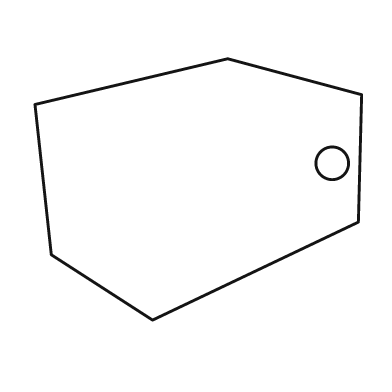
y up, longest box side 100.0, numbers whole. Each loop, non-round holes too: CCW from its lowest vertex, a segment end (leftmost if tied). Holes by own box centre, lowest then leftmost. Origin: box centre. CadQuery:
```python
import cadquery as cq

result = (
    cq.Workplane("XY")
    .moveTo(-14.0, -40.0)
    .lineTo(49.0, -10.0)
    .lineTo(50.0, 29.0)
    .lineTo(9.0, 40.0)
    .lineTo(-50.0, 26.0)
    .lineTo(-45.0, -20.0)
    .close()
    .moveTo(41.0, 8.0)
    .circle(5.0)
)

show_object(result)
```